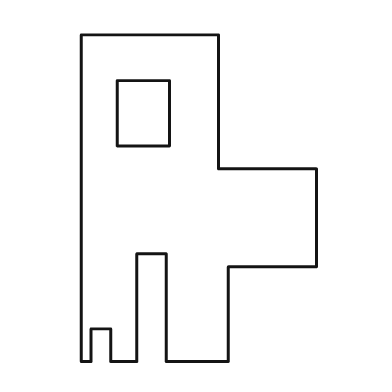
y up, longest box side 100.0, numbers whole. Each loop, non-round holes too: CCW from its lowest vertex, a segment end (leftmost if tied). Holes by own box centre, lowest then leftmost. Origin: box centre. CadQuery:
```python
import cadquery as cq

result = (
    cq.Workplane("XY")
    .moveTo(-36.0, -50.0)
    .lineTo(-33.0, -50.0)
    .lineTo(-33.0, -40.0)
    .lineTo(-27.0, -40.0)
    .lineTo(-27.0, -50.0)
    .lineTo(-19.0, -50.0)
    .lineTo(-19.0, -17.0)
    .lineTo(-10.0, -17.0)
    .lineTo(-10.0, -50.0)
    .lineTo(9.0, -50.0)
    .lineTo(9.0, -21.0)
    .lineTo(36.0, -21.0)
    .lineTo(36.0, 9.0)
    .lineTo(6.0, 9.0)
    .lineTo(6.0, 50.0)
    .lineTo(-36.0, 50.0)
    .close()
    .moveTo(-25.0, 16.0)
    .lineTo(-9.0, 16.0)
    .lineTo(-9.0, 36.0)
    .lineTo(-25.0, 36.0)
    .close()
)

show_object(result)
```